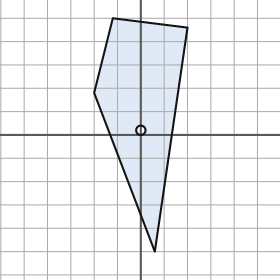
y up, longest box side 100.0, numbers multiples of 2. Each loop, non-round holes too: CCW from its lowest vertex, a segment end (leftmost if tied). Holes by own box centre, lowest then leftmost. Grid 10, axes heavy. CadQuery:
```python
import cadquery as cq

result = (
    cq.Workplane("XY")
    .moveTo(6.0, -50.0)
    .lineTo(20.0, 46.0)
    .lineTo(-12.0, 50.0)
    .lineTo(-20.0, 18.0)
    .close()
    .moveTo(0.0, 2.0)
    .circle(2.0)
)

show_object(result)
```